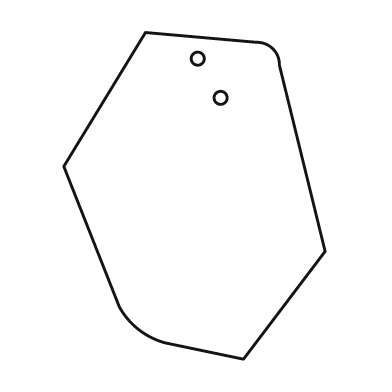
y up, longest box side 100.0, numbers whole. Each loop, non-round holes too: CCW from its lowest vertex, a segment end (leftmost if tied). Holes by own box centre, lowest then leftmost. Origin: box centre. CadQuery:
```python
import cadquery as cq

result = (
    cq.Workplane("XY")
    .moveTo(15.0, -50.0)
    .lineTo(40.0, -17.0)
    .lineTo(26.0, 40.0)
    .threePointArc((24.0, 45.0), (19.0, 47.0))
    .lineTo(-15.0, 50.0)
    .lineTo(-40.0, 9.0)
    .lineTo(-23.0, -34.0)
    .threePointArc((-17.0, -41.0), (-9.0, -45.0))
    .close()
    .moveTo(8.0, 30.0)
    .circle(2.0)
    .moveTo(1.0, 42.0)
    .circle(2.0)
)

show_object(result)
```